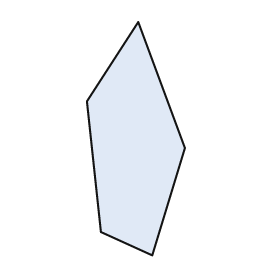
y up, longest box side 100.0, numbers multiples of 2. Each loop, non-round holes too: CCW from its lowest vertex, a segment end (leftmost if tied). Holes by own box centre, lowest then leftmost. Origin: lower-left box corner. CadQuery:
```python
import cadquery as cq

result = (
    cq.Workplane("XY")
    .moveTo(28.0, 0.0)
    .lineTo(42.0, 46.0)
    .lineTo(22.0, 100.0)
    .lineTo(0.0, 66.0)
    .lineTo(6.0, 10.0)
    .close()
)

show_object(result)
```